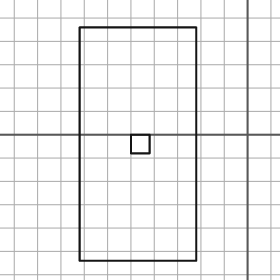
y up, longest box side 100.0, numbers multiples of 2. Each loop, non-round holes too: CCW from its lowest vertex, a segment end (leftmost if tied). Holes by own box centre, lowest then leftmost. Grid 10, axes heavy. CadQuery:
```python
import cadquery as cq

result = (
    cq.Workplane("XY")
    .moveTo(-72.0, -54.0)
    .lineTo(-22.0, -54.0)
    .lineTo(-22.0, 46.0)
    .lineTo(-72.0, 46.0)
    .close()
    .moveTo(-50.0, -8.0)
    .lineTo(-42.0, -8.0)
    .lineTo(-42.0, 0.0)
    .lineTo(-50.0, 0.0)
    .close()
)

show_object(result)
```